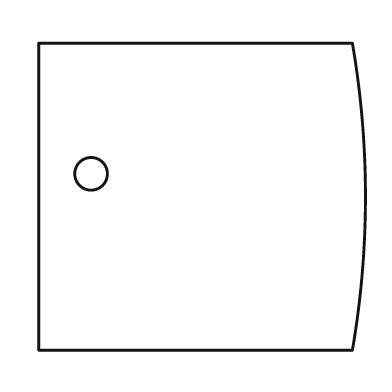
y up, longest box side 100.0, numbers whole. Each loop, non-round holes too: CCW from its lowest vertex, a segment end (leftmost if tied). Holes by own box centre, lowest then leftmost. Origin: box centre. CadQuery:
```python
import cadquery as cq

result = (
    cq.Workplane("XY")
    .moveTo(-50.0, -47.0)
    .lineTo(46.0, -47.0)
    .threePointArc((50.0, 0.0), (46.0, 47.0))
    .lineTo(-50.0, 47.0)
    .close()
    .moveTo(-34.0, 7.0)
    .circle(5.0)
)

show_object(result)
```